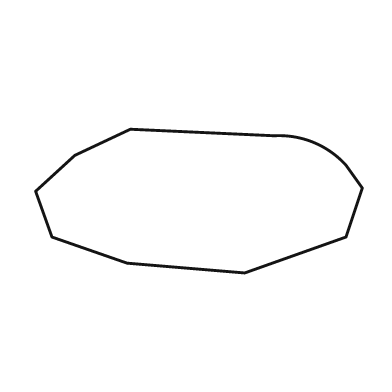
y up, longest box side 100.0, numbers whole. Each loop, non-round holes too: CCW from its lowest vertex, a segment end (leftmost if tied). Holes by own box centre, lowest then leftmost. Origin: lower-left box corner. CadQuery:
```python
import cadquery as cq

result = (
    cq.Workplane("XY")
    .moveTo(64.0, 0.0)
    .lineTo(95.0, 11.0)
    .lineTo(100.0, 26.0)
    .lineTo(95.0, 33.0)
    .threePointArc((85.0, 40.0), (73.0, 42.0))
    .lineTo(29.0, 44.0)
    .lineTo(12.0, 36.0)
    .lineTo(0.0, 25.0)
    .lineTo(5.0, 11.0)
    .lineTo(28.0, 3.0)
    .close()
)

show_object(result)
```